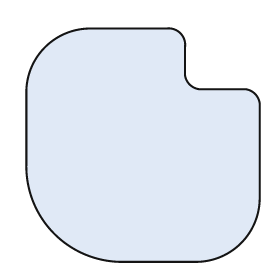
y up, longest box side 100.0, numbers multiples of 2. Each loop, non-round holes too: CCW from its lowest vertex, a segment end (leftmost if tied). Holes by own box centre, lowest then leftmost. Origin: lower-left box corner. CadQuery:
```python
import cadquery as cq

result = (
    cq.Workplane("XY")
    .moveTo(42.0, 0.0)
    .lineTo(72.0, 0.0)
    .threePointArc((92.0, 8.0), (100.0, 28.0))
    .lineTo(100.0, 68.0)
    .threePointArc((98.0, 72.0), (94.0, 74.0))
    .lineTo(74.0, 74.0)
    .threePointArc((70.0, 76.0), (68.0, 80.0))
    .lineTo(68.0, 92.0)
    .threePointArc((66.0, 98.0), (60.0, 100.0))
    .lineTo(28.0, 100.0)
    .threePointArc((8.0, 92.0), (0.0, 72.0))
    .lineTo(0.0, 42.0)
    .threePointArc((12.0, 12.0), (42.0, 0.0))
    .close()
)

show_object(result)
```